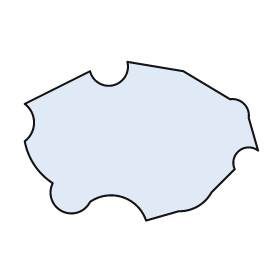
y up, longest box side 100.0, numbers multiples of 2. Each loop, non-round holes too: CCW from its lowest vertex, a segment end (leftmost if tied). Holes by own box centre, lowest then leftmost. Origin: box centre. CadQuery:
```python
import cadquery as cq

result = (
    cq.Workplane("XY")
    .moveTo(2.0, -34.0)
    .lineTo(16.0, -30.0)
    .threePointArc((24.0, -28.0), (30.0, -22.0))
    .lineTo(40.0, -12.0)
    .threePointArc((42.0, -4.0), (50.0, -4.0))
    .lineTo(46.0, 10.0)
    .threePointArc((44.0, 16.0), (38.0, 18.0))
    .lineTo(18.0, 30.0)
    .lineTo(-6.0, 34.0)
    .threePointArc((-12.0, 24.0), (-22.0, 30.0))
    .lineTo(-50.0, 16.0)
    .threePointArc((-46.0, 8.0), (-50.0, 0.0))
    .threePointArc((-46.0, -10.0), (-38.0, -18.0))
    .threePointArc((-34.0, -30.0), (-22.0, -26.0))
    .threePointArc((-8.0, -24.0), (2.0, -34.0))
    .close()
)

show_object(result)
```